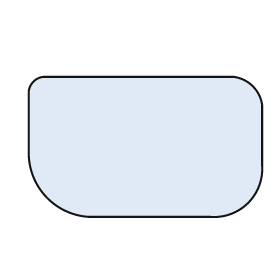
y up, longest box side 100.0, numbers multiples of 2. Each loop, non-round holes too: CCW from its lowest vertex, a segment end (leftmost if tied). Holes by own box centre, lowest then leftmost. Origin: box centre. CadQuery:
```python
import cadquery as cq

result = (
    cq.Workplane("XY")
    .moveTo(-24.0, -30.0)
    .lineTo(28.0, -30.0)
    .threePointArc((44.0, -24.0), (50.0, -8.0))
    .lineTo(50.0, 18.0)
    .threePointArc((46.0, 26.0), (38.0, 30.0))
    .lineTo(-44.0, 30.0)
    .threePointArc((-48.0, 28.0), (-50.0, 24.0))
    .lineTo(-50.0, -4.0)
    .threePointArc((-42.0, -22.0), (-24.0, -30.0))
    .close()
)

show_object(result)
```